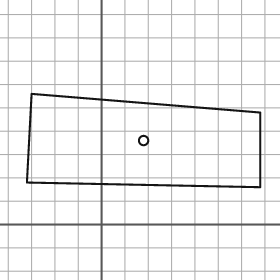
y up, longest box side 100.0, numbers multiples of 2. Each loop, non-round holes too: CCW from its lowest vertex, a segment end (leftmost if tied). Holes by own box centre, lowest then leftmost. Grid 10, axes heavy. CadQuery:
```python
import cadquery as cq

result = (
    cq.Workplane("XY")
    .moveTo(68.0, 16.0)
    .lineTo(68.0, 48.0)
    .lineTo(-30.0, 56.0)
    .lineTo(-32.0, 18.0)
    .close()
    .moveTo(18.0, 36.0)
    .circle(2.0)
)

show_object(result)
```